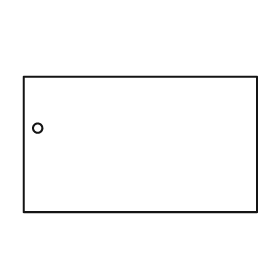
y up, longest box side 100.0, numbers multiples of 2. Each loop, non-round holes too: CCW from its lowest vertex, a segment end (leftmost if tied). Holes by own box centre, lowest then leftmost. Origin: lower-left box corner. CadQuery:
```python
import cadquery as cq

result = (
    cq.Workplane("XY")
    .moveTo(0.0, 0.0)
    .lineTo(100.0, 0.0)
    .lineTo(100.0, 58.0)
    .lineTo(0.0, 58.0)
    .close()
    .moveTo(6.0, 36.0)
    .circle(2.0)
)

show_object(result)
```